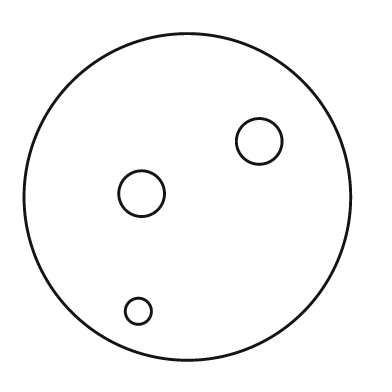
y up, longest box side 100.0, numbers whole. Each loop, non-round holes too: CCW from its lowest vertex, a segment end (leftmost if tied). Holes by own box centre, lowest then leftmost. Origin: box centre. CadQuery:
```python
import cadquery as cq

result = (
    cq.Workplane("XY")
    .moveTo(0.0, 0.0)
    .circle(50.0)
    .moveTo(-15.0, -35.0)
    .circle(4.0)
    .moveTo(-14.0, 1.0)
    .circle(7.0)
    .moveTo(22.0, 17.0)
    .circle(7.0)
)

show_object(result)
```